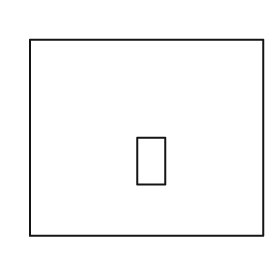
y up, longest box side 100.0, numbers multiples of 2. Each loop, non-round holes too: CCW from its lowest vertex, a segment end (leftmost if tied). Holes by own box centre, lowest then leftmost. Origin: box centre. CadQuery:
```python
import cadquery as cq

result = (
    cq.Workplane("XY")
    .moveTo(-50.0, -42.0)
    .lineTo(50.0, -42.0)
    .lineTo(50.0, 42.0)
    .lineTo(-50.0, 42.0)
    .close()
    .moveTo(-4.0, -20.0)
    .lineTo(8.0, -20.0)
    .lineTo(8.0, 0.0)
    .lineTo(-4.0, 0.0)
    .close()
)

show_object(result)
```